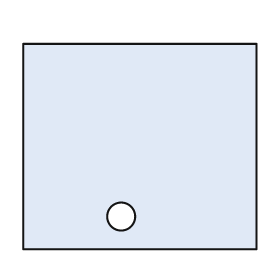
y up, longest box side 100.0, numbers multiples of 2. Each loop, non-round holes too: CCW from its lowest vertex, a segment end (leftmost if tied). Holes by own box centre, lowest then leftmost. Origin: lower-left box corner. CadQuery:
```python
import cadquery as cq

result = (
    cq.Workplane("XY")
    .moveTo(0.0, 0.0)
    .lineTo(100.0, 0.0)
    .lineTo(100.0, 88.0)
    .lineTo(0.0, 88.0)
    .close()
    .moveTo(42.0, 14.0)
    .circle(6.0)
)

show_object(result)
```